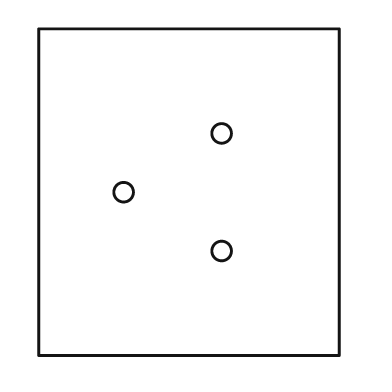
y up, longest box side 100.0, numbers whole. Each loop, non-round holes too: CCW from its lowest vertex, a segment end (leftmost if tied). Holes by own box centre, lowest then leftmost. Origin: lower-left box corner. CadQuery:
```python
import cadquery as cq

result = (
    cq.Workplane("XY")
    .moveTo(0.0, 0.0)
    .lineTo(92.0, 0.0)
    .lineTo(92.0, 100.0)
    .lineTo(0.0, 100.0)
    .close()
    .moveTo(56.0, 32.0)
    .circle(3.0)
    .moveTo(26.0, 50.0)
    .circle(3.0)
    .moveTo(56.0, 68.0)
    .circle(3.0)
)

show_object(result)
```